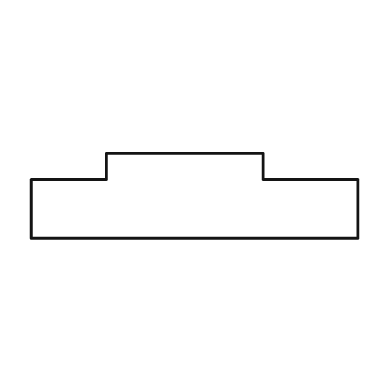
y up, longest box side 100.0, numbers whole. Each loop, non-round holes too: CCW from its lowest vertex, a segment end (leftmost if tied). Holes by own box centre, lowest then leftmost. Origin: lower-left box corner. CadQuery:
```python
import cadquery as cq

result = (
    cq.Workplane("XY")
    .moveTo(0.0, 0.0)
    .lineTo(100.0, 0.0)
    .lineTo(100.0, 18.0)
    .lineTo(71.0, 18.0)
    .lineTo(71.0, 26.0)
    .lineTo(23.0, 26.0)
    .lineTo(23.0, 18.0)
    .lineTo(0.0, 18.0)
    .close()
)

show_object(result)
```